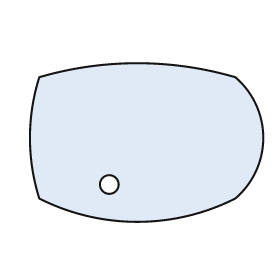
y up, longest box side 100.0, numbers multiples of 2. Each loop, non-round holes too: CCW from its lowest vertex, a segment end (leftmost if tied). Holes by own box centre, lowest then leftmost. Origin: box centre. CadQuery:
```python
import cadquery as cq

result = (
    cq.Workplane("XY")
    .moveTo(-46.0, -24.0)
    .threePointArc((-4.0, -34.0), (38.0, -24.0))
    .threePointArc((50.0, 2.0), (38.0, 28.0))
    .threePointArc((-4.0, 34.0), (-46.0, 28.0))
    .threePointArc((-50.0, 2.0), (-46.0, -24.0))
    .close()
    .moveTo(-16.0, -18.0)
    .circle(4.0)
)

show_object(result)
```